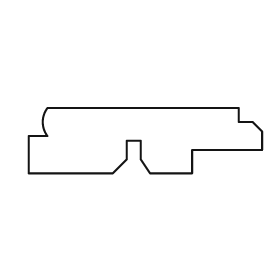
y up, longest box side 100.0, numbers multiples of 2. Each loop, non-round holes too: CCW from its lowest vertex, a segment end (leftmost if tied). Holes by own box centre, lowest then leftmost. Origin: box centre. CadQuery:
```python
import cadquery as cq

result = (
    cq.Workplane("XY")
    .moveTo(-50.0, -14.0)
    .lineTo(-14.0, -14.0)
    .lineTo(-8.0, -8.0)
    .lineTo(-8.0, 0.0)
    .lineTo(-2.0, 0.0)
    .lineTo(-2.0, -8.0)
    .lineTo(2.0, -14.0)
    .lineTo(20.0, -14.0)
    .lineTo(20.0, -4.0)
    .lineTo(50.0, -4.0)
    .lineTo(50.0, 4.0)
    .lineTo(46.0, 8.0)
    .lineTo(40.0, 8.0)
    .lineTo(40.0, 14.0)
    .lineTo(-42.0, 14.0)
    .threePointArc((-44.0, 8.0), (-42.0, 2.0))
    .lineTo(-50.0, 2.0)
    .close()
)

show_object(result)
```